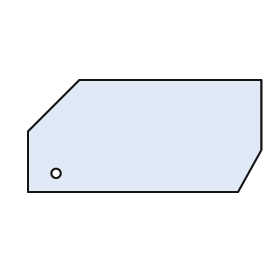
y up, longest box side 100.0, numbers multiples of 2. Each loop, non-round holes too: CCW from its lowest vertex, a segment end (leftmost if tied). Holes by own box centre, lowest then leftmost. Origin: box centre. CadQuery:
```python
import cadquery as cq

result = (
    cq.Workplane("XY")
    .moveTo(-50.0, -24.0)
    .lineTo(40.0, -24.0)
    .lineTo(50.0, -6.0)
    .lineTo(50.0, 24.0)
    .lineTo(-28.0, 24.0)
    .lineTo(-50.0, 2.0)
    .close()
    .moveTo(-38.0, -16.0)
    .circle(2.0)
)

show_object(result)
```